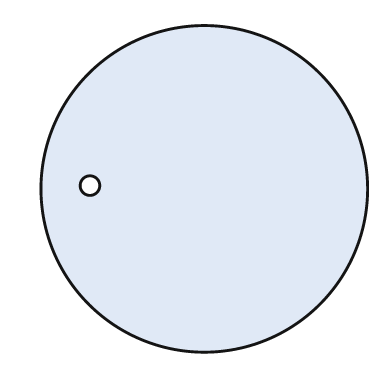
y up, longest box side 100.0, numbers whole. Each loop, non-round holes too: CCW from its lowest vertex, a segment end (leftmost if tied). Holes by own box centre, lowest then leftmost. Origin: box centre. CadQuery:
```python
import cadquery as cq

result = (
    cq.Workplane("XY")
    .moveTo(0.0, 0.0)
    .circle(50.0)
    .moveTo(-35.0, 1.0)
    .circle(3.0)
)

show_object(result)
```